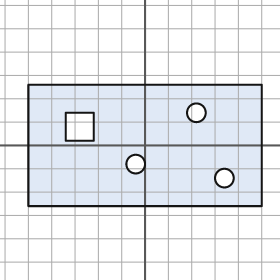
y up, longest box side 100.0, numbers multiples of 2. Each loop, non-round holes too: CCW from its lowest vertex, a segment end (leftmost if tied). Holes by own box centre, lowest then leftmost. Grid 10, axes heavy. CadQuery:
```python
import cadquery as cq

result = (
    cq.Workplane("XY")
    .moveTo(-50.0, -26.0)
    .lineTo(50.0, -26.0)
    .lineTo(50.0, 26.0)
    .lineTo(-50.0, 26.0)
    .close()
    .moveTo(34.0, -14.0)
    .circle(4.0)
    .moveTo(-4.0, -8.0)
    .circle(4.0)
    .moveTo(-34.0, 2.0)
    .lineTo(-22.0, 2.0)
    .lineTo(-22.0, 14.0)
    .lineTo(-34.0, 14.0)
    .close()
    .moveTo(22.0, 14.0)
    .circle(4.0)
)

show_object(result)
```